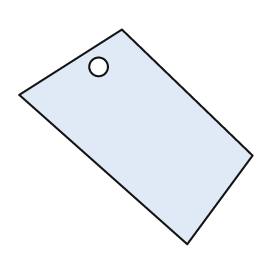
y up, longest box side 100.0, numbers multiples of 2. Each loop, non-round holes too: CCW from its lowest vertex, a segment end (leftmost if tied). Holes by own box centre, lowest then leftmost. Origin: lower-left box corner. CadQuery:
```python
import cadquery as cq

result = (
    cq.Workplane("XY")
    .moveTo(72.0, 0.0)
    .lineTo(100.0, 38.0)
    .lineTo(44.0, 92.0)
    .lineTo(0.0, 64.0)
    .close()
    .moveTo(34.0, 76.0)
    .circle(4.0)
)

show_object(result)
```